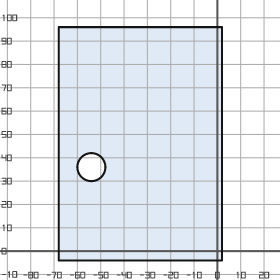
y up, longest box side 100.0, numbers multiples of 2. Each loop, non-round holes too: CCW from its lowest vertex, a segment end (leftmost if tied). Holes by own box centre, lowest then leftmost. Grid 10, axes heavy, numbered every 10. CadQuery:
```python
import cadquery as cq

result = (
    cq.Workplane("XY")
    .moveTo(-68.0, -4.0)
    .lineTo(2.0, -4.0)
    .lineTo(2.0, 96.0)
    .lineTo(-68.0, 96.0)
    .close()
    .moveTo(-54.0, 36.0)
    .circle(6.0)
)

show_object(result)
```